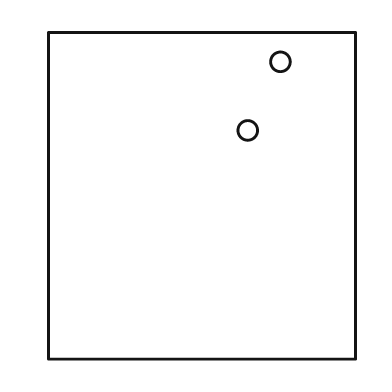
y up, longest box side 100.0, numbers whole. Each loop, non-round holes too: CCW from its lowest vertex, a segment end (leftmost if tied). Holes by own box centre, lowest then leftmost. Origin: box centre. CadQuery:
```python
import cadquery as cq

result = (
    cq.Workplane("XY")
    .moveTo(-47.0, -50.0)
    .lineTo(47.0, -50.0)
    .lineTo(47.0, 50.0)
    .lineTo(-47.0, 50.0)
    .close()
    .moveTo(14.0, 20.0)
    .circle(3.0)
    .moveTo(24.0, 41.0)
    .circle(3.0)
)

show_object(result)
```